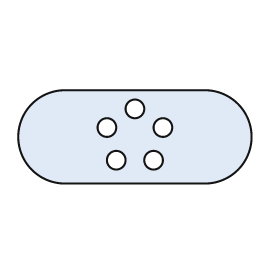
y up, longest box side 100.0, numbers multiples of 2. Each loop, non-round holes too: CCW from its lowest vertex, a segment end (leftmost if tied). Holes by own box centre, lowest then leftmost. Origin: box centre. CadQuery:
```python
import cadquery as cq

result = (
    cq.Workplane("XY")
    .moveTo(-30.0, -20.0)
    .lineTo(30.0, -20.0)
    .threePointArc((50.0, 0.0), (30.0, 20.0))
    .lineTo(-30.0, 20.0)
    .threePointArc((-50.0, 0.0), (-30.0, -20.0))
    .close()
    .moveTo(-8.0, -10.0)
    .circle(4.0)
    .moveTo(8.0, -10.0)
    .circle(4.0)
    .moveTo(-12.0, 4.0)
    .circle(4.0)
    .moveTo(12.0, 4.0)
    .circle(4.0)
    .moveTo(0.0, 12.0)
    .circle(4.0)
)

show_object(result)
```